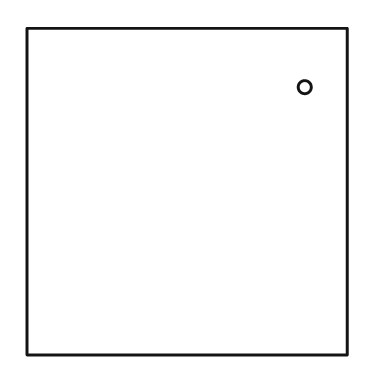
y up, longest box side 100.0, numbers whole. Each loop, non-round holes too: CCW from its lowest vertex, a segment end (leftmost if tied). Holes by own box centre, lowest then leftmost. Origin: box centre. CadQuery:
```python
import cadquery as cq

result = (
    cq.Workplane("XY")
    .moveTo(-49.0, -50.0)
    .lineTo(49.0, -50.0)
    .lineTo(49.0, 50.0)
    .lineTo(-49.0, 50.0)
    .close()
    .moveTo(36.0, 32.0)
    .circle(2.0)
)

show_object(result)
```